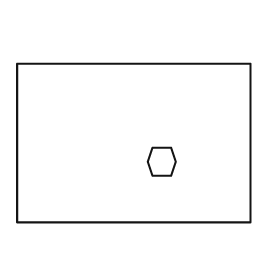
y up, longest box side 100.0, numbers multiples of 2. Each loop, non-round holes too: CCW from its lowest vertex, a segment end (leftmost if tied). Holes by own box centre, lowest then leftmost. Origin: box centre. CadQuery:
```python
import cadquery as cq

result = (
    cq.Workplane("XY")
    .moveTo(-50.0, -34.0)
    .lineTo(50.0, -34.0)
    .lineTo(50.0, 34.0)
    .lineTo(-50.0, 34.0)
    .close()
    .moveTo(8.0, -14.0)
    .lineTo(16.0, -14.0)
    .lineTo(18.0, -8.0)
    .lineTo(16.0, -2.0)
    .lineTo(8.0, -2.0)
    .lineTo(6.0, -8.0)
    .close()
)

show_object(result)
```